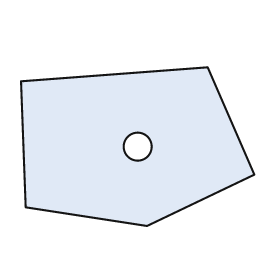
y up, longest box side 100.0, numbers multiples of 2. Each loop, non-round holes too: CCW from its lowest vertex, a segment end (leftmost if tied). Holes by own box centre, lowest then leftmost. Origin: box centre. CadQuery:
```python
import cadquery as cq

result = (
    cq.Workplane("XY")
    .moveTo(4.0, -34.0)
    .lineTo(50.0, -12.0)
    .lineTo(30.0, 34.0)
    .lineTo(-50.0, 28.0)
    .lineTo(-48.0, -26.0)
    .close()
    .moveTo(0.0, 0.0)
    .circle(6.0)
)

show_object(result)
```